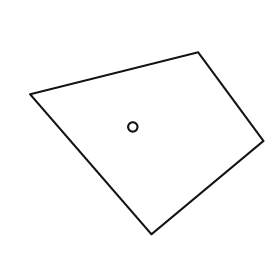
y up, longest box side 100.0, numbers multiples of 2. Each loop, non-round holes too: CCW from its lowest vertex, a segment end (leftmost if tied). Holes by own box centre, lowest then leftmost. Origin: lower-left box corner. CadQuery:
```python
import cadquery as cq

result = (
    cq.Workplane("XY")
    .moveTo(52.0, 0.0)
    .lineTo(100.0, 40.0)
    .lineTo(72.0, 78.0)
    .lineTo(0.0, 60.0)
    .close()
    .moveTo(44.0, 46.0)
    .circle(2.0)
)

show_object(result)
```